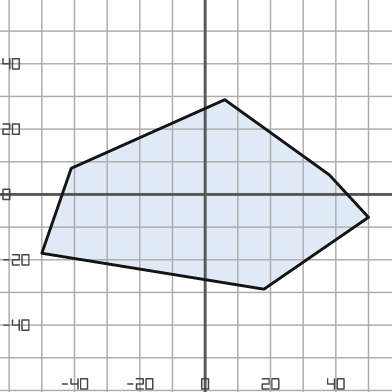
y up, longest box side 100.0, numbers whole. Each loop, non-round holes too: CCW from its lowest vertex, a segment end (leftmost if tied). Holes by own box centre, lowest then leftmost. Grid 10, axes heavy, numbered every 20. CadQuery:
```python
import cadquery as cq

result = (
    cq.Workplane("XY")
    .moveTo(18.0, -29.0)
    .lineTo(50.0, -7.0)
    .lineTo(38.0, 6.0)
    .lineTo(6.0, 29.0)
    .lineTo(-41.0, 8.0)
    .lineTo(-50.0, -18.0)
    .close()
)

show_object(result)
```